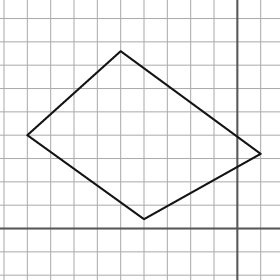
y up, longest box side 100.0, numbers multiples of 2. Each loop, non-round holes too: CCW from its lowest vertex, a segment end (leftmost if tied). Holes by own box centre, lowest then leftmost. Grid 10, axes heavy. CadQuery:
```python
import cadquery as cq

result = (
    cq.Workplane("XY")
    .moveTo(-40.0, 4.0)
    .lineTo(10.0, 32.0)
    .lineTo(-50.0, 76.0)
    .lineTo(-90.0, 40.0)
    .close()
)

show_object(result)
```